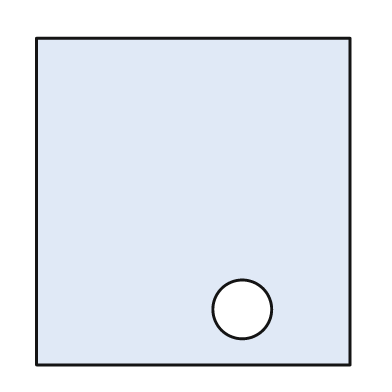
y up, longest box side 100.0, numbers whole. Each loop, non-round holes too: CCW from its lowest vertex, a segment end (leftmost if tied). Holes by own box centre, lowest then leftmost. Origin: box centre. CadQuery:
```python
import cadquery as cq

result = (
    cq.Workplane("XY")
    .moveTo(-48.0, -50.0)
    .lineTo(48.0, -50.0)
    .lineTo(48.0, 50.0)
    .lineTo(-48.0, 50.0)
    .close()
    .moveTo(15.0, -33.0)
    .circle(9.0)
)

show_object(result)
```